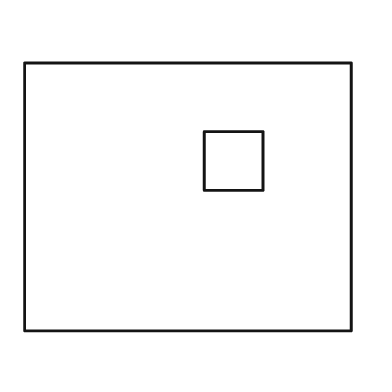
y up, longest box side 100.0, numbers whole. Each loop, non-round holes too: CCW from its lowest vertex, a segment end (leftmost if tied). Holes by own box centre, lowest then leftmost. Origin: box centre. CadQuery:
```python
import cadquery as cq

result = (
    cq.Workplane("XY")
    .moveTo(-50.0, -41.0)
    .lineTo(50.0, -41.0)
    .lineTo(50.0, 41.0)
    .lineTo(-50.0, 41.0)
    .close()
    .moveTo(5.0, 2.0)
    .lineTo(23.0, 2.0)
    .lineTo(23.0, 20.0)
    .lineTo(5.0, 20.0)
    .close()
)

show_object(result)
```